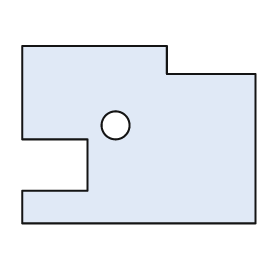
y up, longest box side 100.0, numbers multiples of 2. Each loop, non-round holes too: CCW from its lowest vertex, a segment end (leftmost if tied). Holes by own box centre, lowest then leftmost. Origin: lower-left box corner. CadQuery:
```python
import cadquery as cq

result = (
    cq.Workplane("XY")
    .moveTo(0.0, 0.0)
    .lineTo(100.0, 0.0)
    .lineTo(100.0, 64.0)
    .lineTo(62.0, 64.0)
    .lineTo(62.0, 76.0)
    .lineTo(0.0, 76.0)
    .lineTo(0.0, 36.0)
    .lineTo(28.0, 36.0)
    .lineTo(28.0, 14.0)
    .lineTo(0.0, 14.0)
    .close()
    .moveTo(40.0, 42.0)
    .circle(6.0)
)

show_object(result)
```